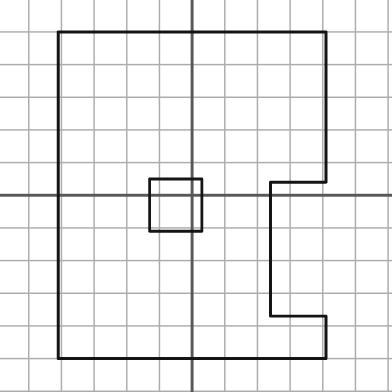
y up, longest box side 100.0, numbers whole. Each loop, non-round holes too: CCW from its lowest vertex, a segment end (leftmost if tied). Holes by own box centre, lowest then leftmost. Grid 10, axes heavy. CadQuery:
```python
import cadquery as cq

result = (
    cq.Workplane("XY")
    .moveTo(-41.0, -50.0)
    .lineTo(41.0, -50.0)
    .lineTo(41.0, -37.0)
    .lineTo(24.0, -37.0)
    .lineTo(24.0, 4.0)
    .lineTo(41.0, 4.0)
    .lineTo(41.0, 50.0)
    .lineTo(-41.0, 50.0)
    .close()
    .moveTo(-13.0, -11.0)
    .lineTo(3.0, -11.0)
    .lineTo(3.0, 5.0)
    .lineTo(-13.0, 5.0)
    .close()
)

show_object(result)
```